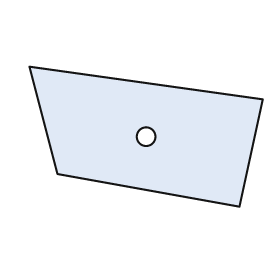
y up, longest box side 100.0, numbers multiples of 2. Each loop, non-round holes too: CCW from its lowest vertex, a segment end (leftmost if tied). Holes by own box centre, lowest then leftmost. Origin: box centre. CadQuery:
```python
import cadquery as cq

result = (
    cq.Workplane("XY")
    .moveTo(40.0, -30.0)
    .lineTo(50.0, 16.0)
    .lineTo(-50.0, 30.0)
    .lineTo(-38.0, -16.0)
    .close()
    .moveTo(0.0, 0.0)
    .circle(4.0)
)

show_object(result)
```